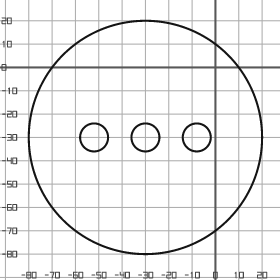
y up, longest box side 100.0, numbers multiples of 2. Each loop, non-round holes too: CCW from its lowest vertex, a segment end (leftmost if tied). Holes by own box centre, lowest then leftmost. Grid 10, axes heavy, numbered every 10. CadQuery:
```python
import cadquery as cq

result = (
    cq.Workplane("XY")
    .moveTo(-30.0, -30.0)
    .circle(50.0)
    .moveTo(-52.0, -30.0)
    .circle(6.0)
    .moveTo(-30.0, -30.0)
    .circle(6.0)
    .moveTo(-8.0, -30.0)
    .circle(6.0)
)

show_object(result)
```